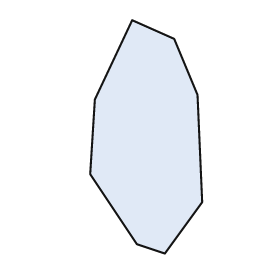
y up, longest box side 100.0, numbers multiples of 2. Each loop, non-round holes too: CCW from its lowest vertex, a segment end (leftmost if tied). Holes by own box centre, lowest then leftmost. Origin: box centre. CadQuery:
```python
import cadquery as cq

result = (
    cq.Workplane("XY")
    .moveTo(8.0, -50.0)
    .lineTo(24.0, -28.0)
    .lineTo(22.0, 18.0)
    .lineTo(12.0, 42.0)
    .lineTo(-6.0, 50.0)
    .lineTo(-22.0, 16.0)
    .lineTo(-24.0, -16.0)
    .lineTo(-4.0, -46.0)
    .close()
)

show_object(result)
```